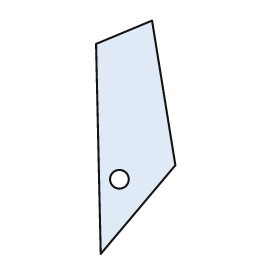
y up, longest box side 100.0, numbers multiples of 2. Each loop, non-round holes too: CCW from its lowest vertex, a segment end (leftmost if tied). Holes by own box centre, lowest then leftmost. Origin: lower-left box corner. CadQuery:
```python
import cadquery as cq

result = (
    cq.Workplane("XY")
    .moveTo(2.0, 0.0)
    .lineTo(34.0, 38.0)
    .lineTo(24.0, 100.0)
    .lineTo(0.0, 90.0)
    .close()
    .moveTo(10.0, 32.0)
    .circle(4.0)
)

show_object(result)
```